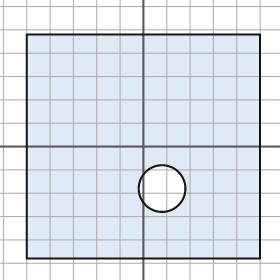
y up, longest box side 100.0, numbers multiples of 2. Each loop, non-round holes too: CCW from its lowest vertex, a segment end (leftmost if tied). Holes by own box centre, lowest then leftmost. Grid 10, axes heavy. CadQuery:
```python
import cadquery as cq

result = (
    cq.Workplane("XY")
    .moveTo(-50.0, -48.0)
    .lineTo(50.0, -48.0)
    .lineTo(50.0, 48.0)
    .lineTo(-50.0, 48.0)
    .close()
    .moveTo(8.0, -18.0)
    .circle(10.0)
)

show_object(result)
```